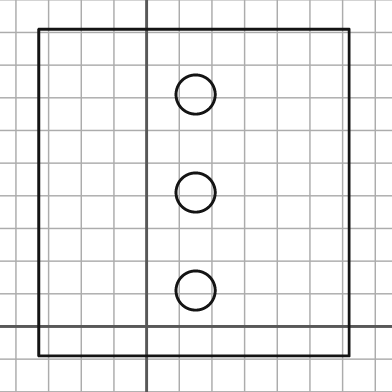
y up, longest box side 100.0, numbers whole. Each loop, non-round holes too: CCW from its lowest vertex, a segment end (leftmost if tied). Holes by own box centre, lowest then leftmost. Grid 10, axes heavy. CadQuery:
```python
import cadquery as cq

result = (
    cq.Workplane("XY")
    .moveTo(-33.0, -9.0)
    .lineTo(62.0, -9.0)
    .lineTo(62.0, 91.0)
    .lineTo(-33.0, 91.0)
    .close()
    .moveTo(15.0, 11.0)
    .circle(6.0)
    .moveTo(15.0, 41.0)
    .circle(6.0)
    .moveTo(15.0, 71.0)
    .circle(6.0)
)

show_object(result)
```